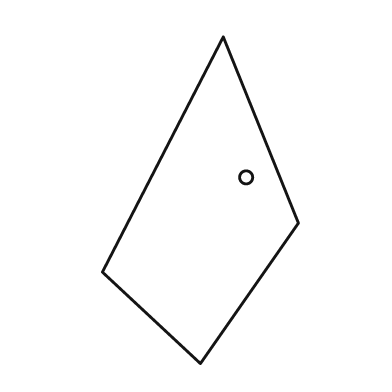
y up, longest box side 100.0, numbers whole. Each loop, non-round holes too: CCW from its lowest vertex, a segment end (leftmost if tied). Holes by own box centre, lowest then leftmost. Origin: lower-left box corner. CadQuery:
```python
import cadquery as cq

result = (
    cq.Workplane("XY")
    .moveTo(30.0, 0.0)
    .lineTo(60.0, 43.0)
    .lineTo(37.0, 100.0)
    .lineTo(0.0, 28.0)
    .close()
    .moveTo(44.0, 57.0)
    .circle(2.0)
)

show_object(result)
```